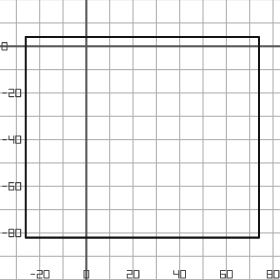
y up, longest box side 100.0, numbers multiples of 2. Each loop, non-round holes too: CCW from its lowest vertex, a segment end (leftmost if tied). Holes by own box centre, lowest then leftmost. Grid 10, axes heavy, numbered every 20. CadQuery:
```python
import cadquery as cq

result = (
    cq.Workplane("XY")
    .moveTo(-26.0, -82.0)
    .lineTo(74.0, -82.0)
    .lineTo(74.0, 4.0)
    .lineTo(-26.0, 4.0)
    .close()
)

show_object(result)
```